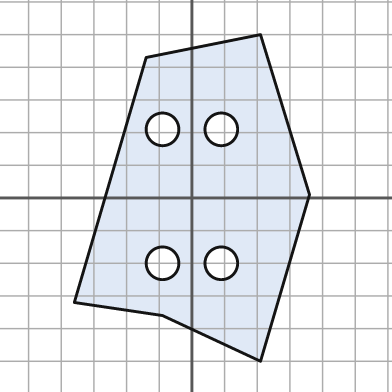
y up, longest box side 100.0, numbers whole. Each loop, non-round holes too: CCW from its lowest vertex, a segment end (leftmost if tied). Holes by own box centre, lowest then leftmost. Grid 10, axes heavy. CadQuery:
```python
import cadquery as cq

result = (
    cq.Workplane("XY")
    .moveTo(21.0, -50.0)
    .lineTo(36.0, 1.0)
    .lineTo(21.0, 50.0)
    .lineTo(-14.0, 43.0)
    .lineTo(-36.0, -32.0)
    .lineTo(-9.0, -36.0)
    .close()
    .moveTo(-9.0, -20.0)
    .circle(5.0)
    .moveTo(9.0, -20.0)
    .circle(5.0)
    .moveTo(-9.0, 21.0)
    .circle(5.0)
    .moveTo(9.0, 21.0)
    .circle(5.0)
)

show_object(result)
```